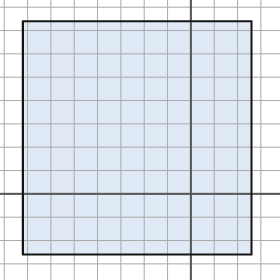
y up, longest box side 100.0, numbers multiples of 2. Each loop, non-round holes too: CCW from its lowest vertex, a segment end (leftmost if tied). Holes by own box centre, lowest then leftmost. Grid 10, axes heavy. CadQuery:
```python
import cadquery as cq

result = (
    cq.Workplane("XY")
    .moveTo(-72.0, -26.0)
    .lineTo(26.0, -26.0)
    .lineTo(26.0, 74.0)
    .lineTo(-72.0, 74.0)
    .close()
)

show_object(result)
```